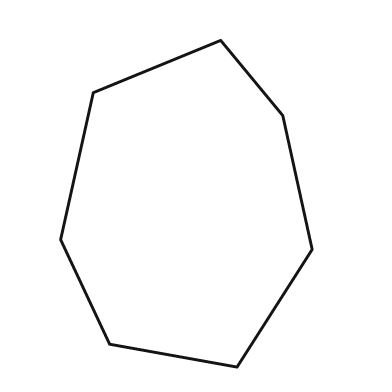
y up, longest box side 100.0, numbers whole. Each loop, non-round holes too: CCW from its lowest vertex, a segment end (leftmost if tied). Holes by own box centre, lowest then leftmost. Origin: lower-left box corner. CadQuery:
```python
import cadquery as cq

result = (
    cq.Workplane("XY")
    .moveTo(54.0, 0.0)
    .lineTo(77.0, 36.0)
    .lineTo(68.0, 77.0)
    .lineTo(49.0, 100.0)
    .lineTo(10.0, 84.0)
    .lineTo(0.0, 39.0)
    .lineTo(15.0, 7.0)
    .close()
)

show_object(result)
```